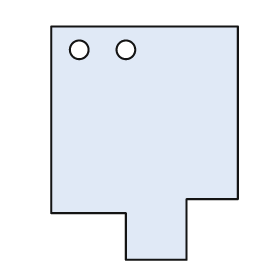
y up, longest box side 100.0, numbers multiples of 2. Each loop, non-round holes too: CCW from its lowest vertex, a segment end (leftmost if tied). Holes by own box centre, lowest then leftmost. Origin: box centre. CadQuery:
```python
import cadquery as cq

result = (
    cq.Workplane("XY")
    .moveTo(-8.0, -50.0)
    .lineTo(18.0, -50.0)
    .lineTo(18.0, -24.0)
    .lineTo(40.0, -24.0)
    .lineTo(40.0, 50.0)
    .lineTo(-40.0, 50.0)
    .lineTo(-40.0, -30.0)
    .lineTo(-8.0, -30.0)
    .close()
    .moveTo(-28.0, 40.0)
    .circle(4.0)
    .moveTo(-8.0, 40.0)
    .circle(4.0)
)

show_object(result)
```